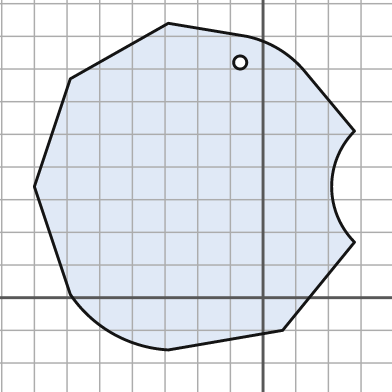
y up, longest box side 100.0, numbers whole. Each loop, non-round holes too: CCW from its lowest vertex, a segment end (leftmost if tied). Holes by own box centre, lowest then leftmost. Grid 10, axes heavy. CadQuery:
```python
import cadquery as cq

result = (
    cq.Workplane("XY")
    .moveTo(-29.0, -16.0)
    .lineTo(6.0, -10.0)
    .lineTo(28.0, 17.0)
    .threePointArc((21.0, 34.0), (28.0, 51.0))
    .lineTo(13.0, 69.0)
    .threePointArc((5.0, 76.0), (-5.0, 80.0))
    .lineTo(-29.0, 84.0)
    .lineTo(-59.0, 67.0)
    .lineTo(-70.0, 34.0)
    .lineTo(-59.0, 1.0)
    .threePointArc((-46.0, -11.0), (-29.0, -16.0))
    .close()
    .moveTo(-7.0, 72.0)
    .circle(2.0)
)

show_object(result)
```